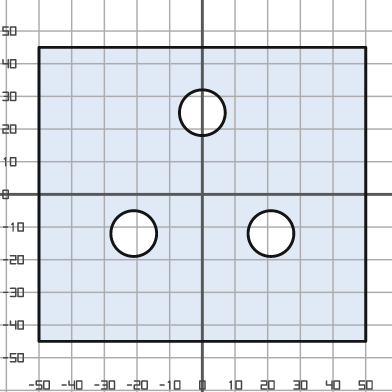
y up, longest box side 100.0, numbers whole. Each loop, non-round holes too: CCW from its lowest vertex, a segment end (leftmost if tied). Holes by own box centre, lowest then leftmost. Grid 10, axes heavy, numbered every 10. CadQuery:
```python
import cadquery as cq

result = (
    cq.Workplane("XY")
    .moveTo(-50.0, -45.0)
    .lineTo(50.0, -45.0)
    .lineTo(50.0, 45.0)
    .lineTo(-50.0, 45.0)
    .close()
    .moveTo(-21.0, -12.0)
    .circle(7.0)
    .moveTo(21.0, -12.0)
    .circle(7.0)
    .moveTo(0.0, 25.0)
    .circle(7.0)
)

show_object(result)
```